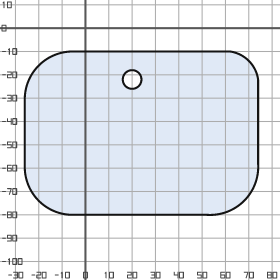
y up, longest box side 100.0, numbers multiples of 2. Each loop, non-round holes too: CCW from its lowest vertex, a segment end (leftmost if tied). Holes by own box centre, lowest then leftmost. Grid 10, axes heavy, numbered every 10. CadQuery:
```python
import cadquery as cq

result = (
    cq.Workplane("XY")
    .moveTo(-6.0, -80.0)
    .lineTo(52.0, -80.0)
    .threePointArc((68.0, -74.0), (74.0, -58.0))
    .lineTo(74.0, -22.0)
    .threePointArc((70.0, -14.0), (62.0, -10.0))
    .lineTo(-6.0, -10.0)
    .threePointArc((-20.0, -16.0), (-26.0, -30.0))
    .lineTo(-26.0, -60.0)
    .threePointArc((-20.0, -74.0), (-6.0, -80.0))
    .close()
    .moveTo(20.0, -22.0)
    .circle(4.0)
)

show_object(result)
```